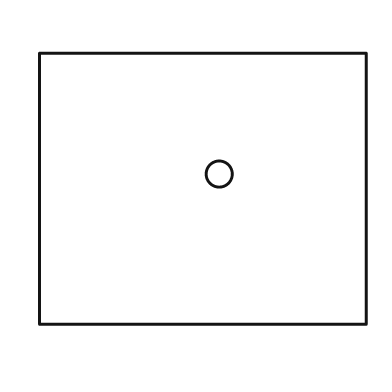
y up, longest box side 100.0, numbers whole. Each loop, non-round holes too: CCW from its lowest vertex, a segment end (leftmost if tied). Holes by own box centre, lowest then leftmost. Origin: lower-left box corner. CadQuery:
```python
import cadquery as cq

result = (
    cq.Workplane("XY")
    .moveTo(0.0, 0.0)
    .lineTo(100.0, 0.0)
    .lineTo(100.0, 83.0)
    .lineTo(0.0, 83.0)
    .close()
    .moveTo(55.0, 46.0)
    .circle(4.0)
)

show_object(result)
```